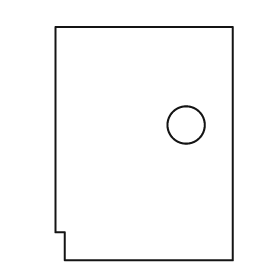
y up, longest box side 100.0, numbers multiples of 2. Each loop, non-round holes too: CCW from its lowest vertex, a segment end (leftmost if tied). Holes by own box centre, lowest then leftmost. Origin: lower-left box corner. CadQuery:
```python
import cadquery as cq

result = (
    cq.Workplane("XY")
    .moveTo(4.0, 0.0)
    .lineTo(76.0, 0.0)
    .lineTo(76.0, 100.0)
    .lineTo(0.0, 100.0)
    .lineTo(0.0, 12.0)
    .lineTo(4.0, 12.0)
    .close()
    .moveTo(56.0, 58.0)
    .circle(8.0)
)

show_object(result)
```